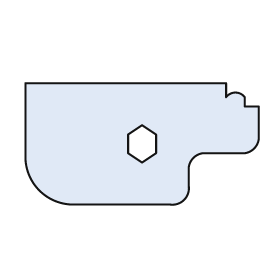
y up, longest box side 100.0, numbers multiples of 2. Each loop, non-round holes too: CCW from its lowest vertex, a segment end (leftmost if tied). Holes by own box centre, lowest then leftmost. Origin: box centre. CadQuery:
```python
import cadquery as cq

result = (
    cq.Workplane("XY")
    .moveTo(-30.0, -26.0)
    .lineTo(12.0, -26.0)
    .threePointArc((18.0, -24.0), (20.0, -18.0))
    .lineTo(20.0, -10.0)
    .threePointArc((22.0, -6.0), (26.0, -4.0))
    .lineTo(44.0, -4.0)
    .threePointArc((48.0, -2.0), (50.0, 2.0))
    .lineTo(50.0, 16.0)
    .lineTo(44.0, 16.0)
    .lineTo(44.0, 20.0)
    .threePointArc((40.0, 22.0), (36.0, 20.0))
    .lineTo(36.0, 26.0)
    .lineTo(-50.0, 26.0)
    .lineTo(-50.0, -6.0)
    .threePointArc((-44.0, -20.0), (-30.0, -26.0))
    .close()
    .moveTo(0.0, -8.0)
    .lineTo(6.0, -4.0)
    .lineTo(6.0, 4.0)
    .lineTo(0.0, 8.0)
    .lineTo(-6.0, 4.0)
    .lineTo(-6.0, -4.0)
    .close()
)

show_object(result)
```